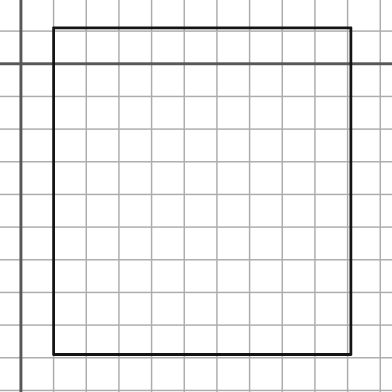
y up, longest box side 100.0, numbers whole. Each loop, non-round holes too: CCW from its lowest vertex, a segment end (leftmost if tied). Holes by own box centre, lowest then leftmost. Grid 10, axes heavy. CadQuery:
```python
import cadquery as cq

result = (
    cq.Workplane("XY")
    .moveTo(10.0, -89.0)
    .lineTo(101.0, -89.0)
    .lineTo(101.0, 11.0)
    .lineTo(10.0, 11.0)
    .close()
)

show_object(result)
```